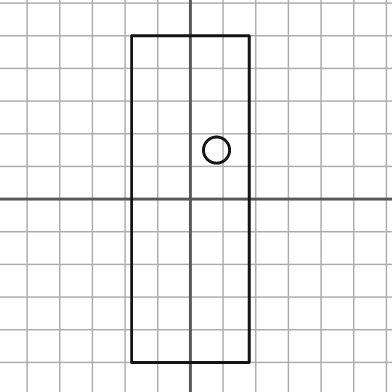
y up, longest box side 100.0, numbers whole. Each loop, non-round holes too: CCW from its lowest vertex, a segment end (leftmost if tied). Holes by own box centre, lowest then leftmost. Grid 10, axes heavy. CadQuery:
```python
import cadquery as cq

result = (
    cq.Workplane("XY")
    .moveTo(-18.0, -50.0)
    .lineTo(18.0, -50.0)
    .lineTo(18.0, 50.0)
    .lineTo(-18.0, 50.0)
    .close()
    .moveTo(8.0, 15.0)
    .circle(4.0)
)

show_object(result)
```